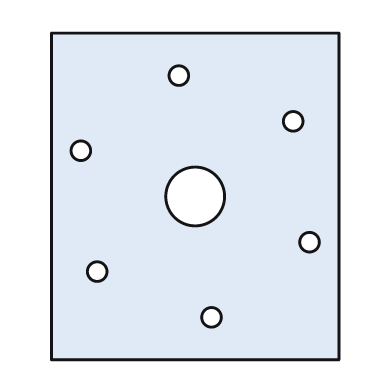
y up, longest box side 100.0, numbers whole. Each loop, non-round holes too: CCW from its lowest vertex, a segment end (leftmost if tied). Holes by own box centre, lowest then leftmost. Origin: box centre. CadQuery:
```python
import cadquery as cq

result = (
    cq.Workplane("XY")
    .moveTo(-44.0, -50.0)
    .lineTo(44.0, -50.0)
    .lineTo(44.0, 50.0)
    .lineTo(-44.0, 50.0)
    .close()
    .moveTo(5.0, -37.0)
    .circle(3.0)
    .moveTo(-30.0, -23.0)
    .circle(3.0)
    .moveTo(35.0, -14.0)
    .circle(3.0)
    .moveTo(0.0, 0.0)
    .circle(9.0)
    .moveTo(-35.0, 14.0)
    .circle(3.0)
    .moveTo(30.0, 23.0)
    .circle(3.0)
    .moveTo(-5.0, 37.0)
    .circle(3.0)
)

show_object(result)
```